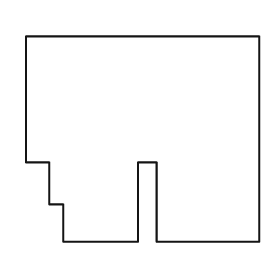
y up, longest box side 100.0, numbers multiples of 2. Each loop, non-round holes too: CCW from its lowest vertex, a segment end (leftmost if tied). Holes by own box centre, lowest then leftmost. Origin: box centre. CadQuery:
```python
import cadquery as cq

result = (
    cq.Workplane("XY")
    .moveTo(-34.0, -44.0)
    .lineTo(-2.0, -44.0)
    .lineTo(-2.0, -10.0)
    .lineTo(6.0, -10.0)
    .lineTo(6.0, -44.0)
    .lineTo(50.0, -44.0)
    .lineTo(50.0, 44.0)
    .lineTo(-50.0, 44.0)
    .lineTo(-50.0, -10.0)
    .lineTo(-40.0, -10.0)
    .lineTo(-40.0, -28.0)
    .lineTo(-34.0, -28.0)
    .close()
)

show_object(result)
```